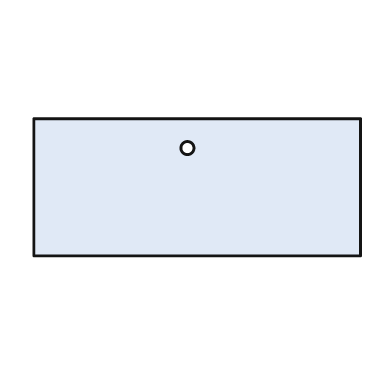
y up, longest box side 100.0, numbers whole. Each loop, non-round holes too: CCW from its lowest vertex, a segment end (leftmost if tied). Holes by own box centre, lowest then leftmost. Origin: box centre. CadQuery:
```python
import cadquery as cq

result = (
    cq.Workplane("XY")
    .moveTo(-50.0, -21.0)
    .lineTo(50.0, -21.0)
    .lineTo(50.0, 21.0)
    .lineTo(-50.0, 21.0)
    .close()
    .moveTo(-3.0, 12.0)
    .circle(2.0)
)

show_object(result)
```